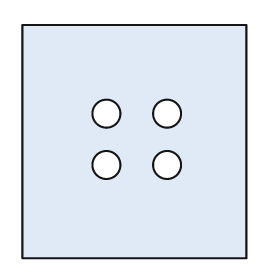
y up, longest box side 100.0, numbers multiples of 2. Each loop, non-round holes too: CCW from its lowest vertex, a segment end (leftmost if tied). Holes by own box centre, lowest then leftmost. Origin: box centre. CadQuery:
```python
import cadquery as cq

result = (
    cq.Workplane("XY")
    .moveTo(-48.0, -50.0)
    .lineTo(48.0, -50.0)
    .lineTo(48.0, 50.0)
    .lineTo(-48.0, 50.0)
    .close()
    .moveTo(-12.0, -10.0)
    .circle(6.0)
    .moveTo(14.0, -10.0)
    .circle(6.0)
    .moveTo(-12.0, 12.0)
    .circle(6.0)
    .moveTo(14.0, 12.0)
    .circle(6.0)
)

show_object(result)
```